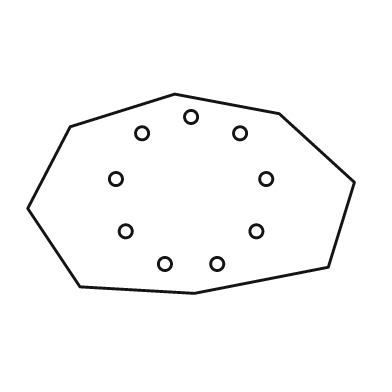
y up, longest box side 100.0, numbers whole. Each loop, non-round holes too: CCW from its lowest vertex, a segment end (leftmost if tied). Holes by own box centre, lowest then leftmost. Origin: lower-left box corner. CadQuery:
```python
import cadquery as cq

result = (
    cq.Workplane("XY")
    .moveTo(51.0, 0.0)
    .lineTo(92.0, 8.0)
    .lineTo(100.0, 34.0)
    .lineTo(77.0, 55.0)
    .lineTo(45.0, 61.0)
    .lineTo(13.0, 51.0)
    .lineTo(0.0, 26.0)
    .lineTo(16.0, 2.0)
    .close()
    .moveTo(42.0, 9.0)
    .circle(2.0)
    .moveTo(58.0, 9.0)
    .circle(2.0)
    .moveTo(30.0, 19.0)
    .circle(2.0)
    .moveTo(70.0, 19.0)
    .circle(2.0)
    .moveTo(27.0, 35.0)
    .circle(2.0)
    .moveTo(73.0, 35.0)
    .circle(2.0)
    .moveTo(35.0, 49.0)
    .circle(2.0)
    .moveTo(65.0, 49.0)
    .circle(2.0)
    .moveTo(50.0, 54.0)
    .circle(2.0)
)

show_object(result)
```